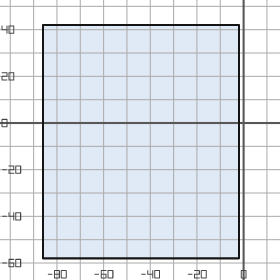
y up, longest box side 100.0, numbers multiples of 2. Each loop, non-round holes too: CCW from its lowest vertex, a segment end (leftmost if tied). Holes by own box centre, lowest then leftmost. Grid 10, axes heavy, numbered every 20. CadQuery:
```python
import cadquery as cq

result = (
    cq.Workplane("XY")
    .moveTo(-86.0, -58.0)
    .lineTo(-2.0, -58.0)
    .lineTo(-2.0, 42.0)
    .lineTo(-86.0, 42.0)
    .close()
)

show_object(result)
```